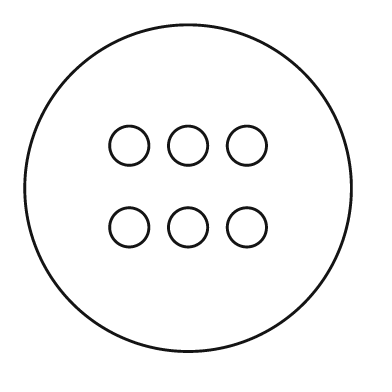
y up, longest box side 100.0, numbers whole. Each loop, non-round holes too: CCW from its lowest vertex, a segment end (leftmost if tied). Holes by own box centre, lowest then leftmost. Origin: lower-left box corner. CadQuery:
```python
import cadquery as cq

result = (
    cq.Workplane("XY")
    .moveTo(50.0, 50.0)
    .circle(50.0)
    .moveTo(32.0, 38.0)
    .circle(6.0)
    .moveTo(50.0, 38.0)
    .circle(6.0)
    .moveTo(68.0, 38.0)
    .circle(6.0)
    .moveTo(32.0, 63.0)
    .circle(6.0)
    .moveTo(50.0, 63.0)
    .circle(6.0)
    .moveTo(68.0, 63.0)
    .circle(6.0)
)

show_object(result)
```